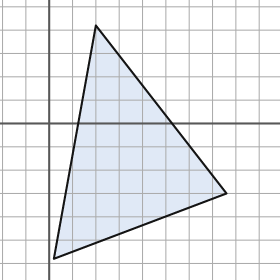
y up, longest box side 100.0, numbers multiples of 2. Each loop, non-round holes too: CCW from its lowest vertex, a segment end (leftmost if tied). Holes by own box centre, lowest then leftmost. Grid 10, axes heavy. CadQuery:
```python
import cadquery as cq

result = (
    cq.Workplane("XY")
    .moveTo(2.0, -58.0)
    .lineTo(76.0, -30.0)
    .lineTo(20.0, 42.0)
    .close()
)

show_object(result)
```